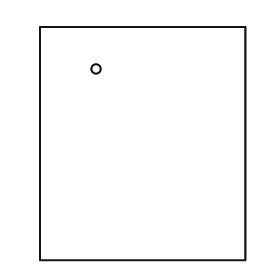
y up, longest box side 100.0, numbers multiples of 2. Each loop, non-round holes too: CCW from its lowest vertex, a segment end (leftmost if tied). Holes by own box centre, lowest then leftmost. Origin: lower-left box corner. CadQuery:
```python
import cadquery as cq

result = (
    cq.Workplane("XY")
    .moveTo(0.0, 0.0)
    .lineTo(88.0, 0.0)
    .lineTo(88.0, 100.0)
    .lineTo(0.0, 100.0)
    .close()
    .moveTo(24.0, 82.0)
    .circle(2.0)
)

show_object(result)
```